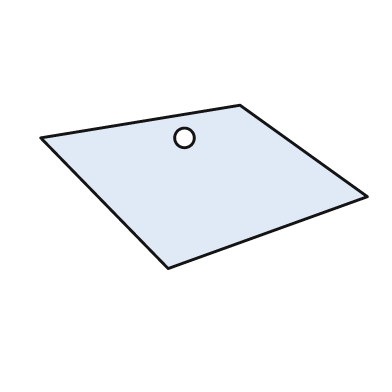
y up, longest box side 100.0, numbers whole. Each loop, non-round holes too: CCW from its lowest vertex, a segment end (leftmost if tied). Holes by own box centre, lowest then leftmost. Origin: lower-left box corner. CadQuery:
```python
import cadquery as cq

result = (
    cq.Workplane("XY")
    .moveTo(39.0, 0.0)
    .lineTo(100.0, 22.0)
    .lineTo(61.0, 50.0)
    .lineTo(0.0, 40.0)
    .close()
    .moveTo(44.0, 40.0)
    .circle(3.0)
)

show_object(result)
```